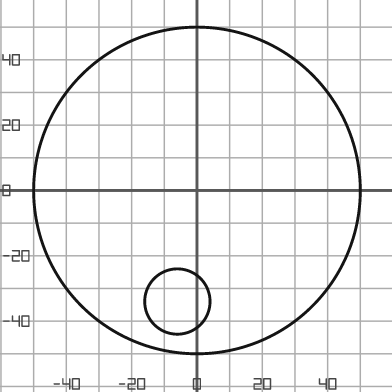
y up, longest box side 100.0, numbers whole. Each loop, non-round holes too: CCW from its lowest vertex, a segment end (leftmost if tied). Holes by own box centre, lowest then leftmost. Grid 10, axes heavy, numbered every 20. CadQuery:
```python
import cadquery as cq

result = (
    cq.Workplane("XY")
    .moveTo(0.0, 0.0)
    .circle(50.0)
    .moveTo(-6.0, -34.0)
    .circle(10.0)
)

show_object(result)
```